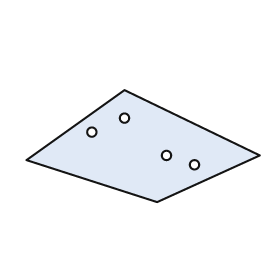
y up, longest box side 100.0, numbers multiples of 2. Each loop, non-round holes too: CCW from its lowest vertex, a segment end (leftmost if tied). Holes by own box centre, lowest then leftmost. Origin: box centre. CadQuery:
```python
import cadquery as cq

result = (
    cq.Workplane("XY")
    .moveTo(6.0, -24.0)
    .lineTo(50.0, -4.0)
    .lineTo(-8.0, 24.0)
    .lineTo(-50.0, -6.0)
    .close()
    .moveTo(22.0, -8.0)
    .circle(2.0)
    .moveTo(10.0, -4.0)
    .circle(2.0)
    .moveTo(-22.0, 6.0)
    .circle(2.0)
    .moveTo(-8.0, 12.0)
    .circle(2.0)
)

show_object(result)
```